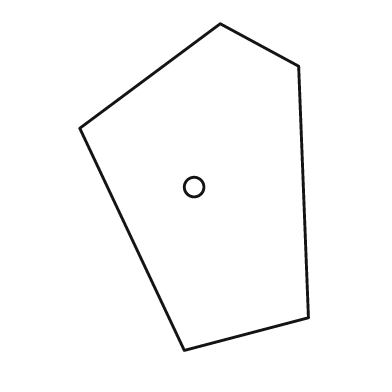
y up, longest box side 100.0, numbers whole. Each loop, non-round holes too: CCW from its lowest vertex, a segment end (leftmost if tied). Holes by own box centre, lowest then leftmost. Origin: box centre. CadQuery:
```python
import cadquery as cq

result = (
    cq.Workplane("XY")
    .moveTo(-3.0, -50.0)
    .lineTo(35.0, -40.0)
    .lineTo(32.0, 37.0)
    .lineTo(8.0, 50.0)
    .lineTo(-35.0, 18.0)
    .close()
    .moveTo(0.0, 0.0)
    .circle(3.0)
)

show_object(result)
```